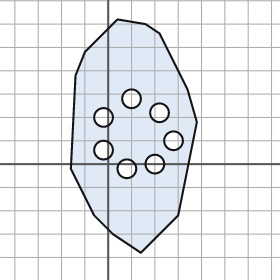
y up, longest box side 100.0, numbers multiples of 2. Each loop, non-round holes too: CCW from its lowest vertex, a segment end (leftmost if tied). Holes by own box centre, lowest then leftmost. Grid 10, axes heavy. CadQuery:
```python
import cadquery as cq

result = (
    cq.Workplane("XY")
    .moveTo(14.0, -38.0)
    .lineTo(30.0, -22.0)
    .lineTo(38.0, 18.0)
    .lineTo(34.0, 32.0)
    .lineTo(22.0, 56.0)
    .lineTo(16.0, 60.0)
    .lineTo(4.0, 62.0)
    .lineTo(-10.0, 48.0)
    .lineTo(-14.0, 38.0)
    .lineTo(-16.0, -2.0)
    .lineTo(-6.0, -22.0)
    .lineTo(2.0, -30.0)
    .close()
    .moveTo(8.0, -2.0)
    .circle(4.0)
    .moveTo(20.0, 0.0)
    .circle(4.0)
    .moveTo(-2.0, 6.0)
    .circle(4.0)
    .moveTo(28.0, 10.0)
    .circle(4.0)
    .moveTo(-2.0, 20.0)
    .circle(4.0)
    .moveTo(22.0, 22.0)
    .circle(4.0)
    .moveTo(10.0, 28.0)
    .circle(4.0)
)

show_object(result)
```